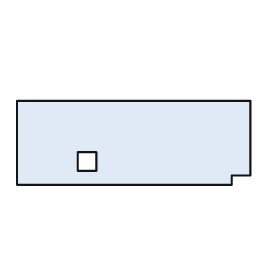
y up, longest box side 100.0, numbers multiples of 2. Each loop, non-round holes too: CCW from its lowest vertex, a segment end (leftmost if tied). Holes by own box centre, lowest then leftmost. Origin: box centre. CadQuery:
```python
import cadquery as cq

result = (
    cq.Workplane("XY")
    .moveTo(-50.0, -18.0)
    .lineTo(42.0, -18.0)
    .lineTo(42.0, -14.0)
    .lineTo(50.0, -14.0)
    .lineTo(50.0, 18.0)
    .lineTo(-50.0, 18.0)
    .close()
    .moveTo(-24.0, -12.0)
    .lineTo(-16.0, -12.0)
    .lineTo(-16.0, -4.0)
    .lineTo(-24.0, -4.0)
    .close()
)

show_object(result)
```